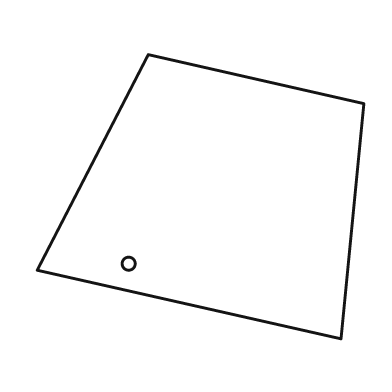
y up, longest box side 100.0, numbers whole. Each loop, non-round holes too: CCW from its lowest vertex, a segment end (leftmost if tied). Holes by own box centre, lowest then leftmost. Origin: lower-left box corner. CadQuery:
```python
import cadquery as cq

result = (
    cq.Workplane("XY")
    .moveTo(93.0, 0.0)
    .lineTo(100.0, 72.0)
    .lineTo(34.0, 87.0)
    .lineTo(0.0, 21.0)
    .close()
    .moveTo(28.0, 23.0)
    .circle(2.0)
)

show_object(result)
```